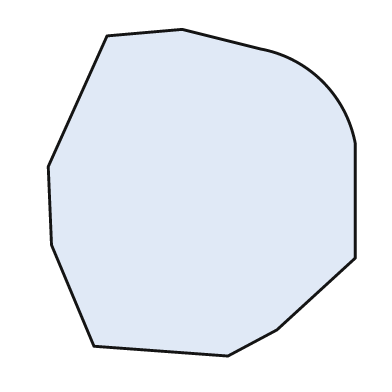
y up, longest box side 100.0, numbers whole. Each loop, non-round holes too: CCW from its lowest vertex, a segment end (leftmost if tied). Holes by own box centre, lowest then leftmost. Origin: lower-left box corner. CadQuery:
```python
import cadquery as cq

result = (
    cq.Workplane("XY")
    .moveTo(55.0, 0.0)
    .lineTo(70.0, 8.0)
    .lineTo(94.0, 30.0)
    .lineTo(94.0, 65.0)
    .threePointArc((84.0, 84.0), (65.0, 94.0))
    .lineTo(41.0, 100.0)
    .lineTo(18.0, 98.0)
    .lineTo(0.0, 58.0)
    .lineTo(1.0, 34.0)
    .lineTo(14.0, 3.0)
    .close()
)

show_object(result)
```